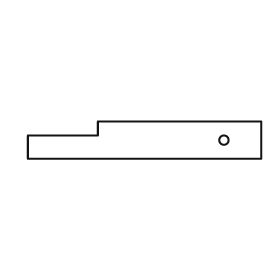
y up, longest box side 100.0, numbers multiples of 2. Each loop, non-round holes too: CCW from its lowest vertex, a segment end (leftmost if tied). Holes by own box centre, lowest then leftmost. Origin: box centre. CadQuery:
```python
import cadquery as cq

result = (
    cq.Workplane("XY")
    .moveTo(-50.0, -8.0)
    .lineTo(50.0, -8.0)
    .lineTo(50.0, 8.0)
    .lineTo(-20.0, 8.0)
    .lineTo(-20.0, 2.0)
    .lineTo(-50.0, 2.0)
    .close()
    .moveTo(34.0, 0.0)
    .circle(2.0)
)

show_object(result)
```